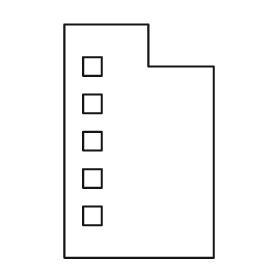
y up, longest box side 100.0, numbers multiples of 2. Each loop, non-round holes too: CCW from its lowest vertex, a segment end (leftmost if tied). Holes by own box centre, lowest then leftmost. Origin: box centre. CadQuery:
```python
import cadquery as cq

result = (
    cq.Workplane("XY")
    .moveTo(-32.0, -50.0)
    .lineTo(32.0, -50.0)
    .lineTo(32.0, 32.0)
    .lineTo(4.0, 32.0)
    .lineTo(4.0, 50.0)
    .lineTo(-32.0, 50.0)
    .close()
    .moveTo(-24.0, -36.0)
    .lineTo(-16.0, -36.0)
    .lineTo(-16.0, -28.0)
    .lineTo(-24.0, -28.0)
    .close()
    .moveTo(-24.0, -20.0)
    .lineTo(-16.0, -20.0)
    .lineTo(-16.0, -12.0)
    .lineTo(-24.0, -12.0)
    .close()
    .moveTo(-24.0, -4.0)
    .lineTo(-16.0, -4.0)
    .lineTo(-16.0, 4.0)
    .lineTo(-24.0, 4.0)
    .close()
    .moveTo(-24.0, 12.0)
    .lineTo(-16.0, 12.0)
    .lineTo(-16.0, 20.0)
    .lineTo(-24.0, 20.0)
    .close()
    .moveTo(-24.0, 28.0)
    .lineTo(-16.0, 28.0)
    .lineTo(-16.0, 36.0)
    .lineTo(-24.0, 36.0)
    .close()
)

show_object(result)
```